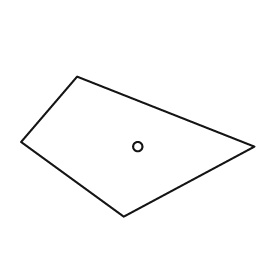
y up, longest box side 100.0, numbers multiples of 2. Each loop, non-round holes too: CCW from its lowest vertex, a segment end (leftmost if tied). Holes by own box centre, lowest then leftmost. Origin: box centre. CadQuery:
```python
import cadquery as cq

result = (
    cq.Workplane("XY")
    .moveTo(-6.0, -30.0)
    .lineTo(50.0, 0.0)
    .lineTo(-26.0, 30.0)
    .lineTo(-50.0, 2.0)
    .close()
    .moveTo(0.0, 0.0)
    .circle(2.0)
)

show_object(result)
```